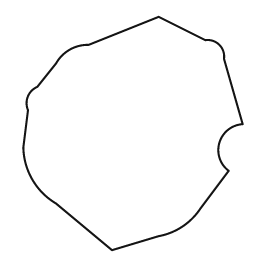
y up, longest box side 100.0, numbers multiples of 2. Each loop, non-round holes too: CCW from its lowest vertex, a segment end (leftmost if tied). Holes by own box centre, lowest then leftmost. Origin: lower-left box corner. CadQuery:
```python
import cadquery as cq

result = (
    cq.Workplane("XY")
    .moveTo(38.0, 0.0)
    .lineTo(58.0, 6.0)
    .threePointArc((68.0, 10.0), (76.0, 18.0))
    .lineTo(88.0, 34.0)
    .threePointArc((84.0, 46.0), (94.0, 54.0))
    .lineTo(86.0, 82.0)
    .threePointArc((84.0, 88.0), (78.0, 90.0))
    .lineTo(58.0, 100.0)
    .lineTo(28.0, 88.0)
    .threePointArc((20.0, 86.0), (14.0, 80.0))
    .lineTo(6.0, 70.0)
    .threePointArc((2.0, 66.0), (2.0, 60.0))
    .lineTo(0.0, 44.0)
    .threePointArc((4.0, 30.0), (14.0, 20.0))
    .close()
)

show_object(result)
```